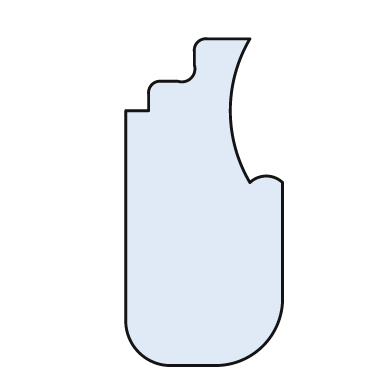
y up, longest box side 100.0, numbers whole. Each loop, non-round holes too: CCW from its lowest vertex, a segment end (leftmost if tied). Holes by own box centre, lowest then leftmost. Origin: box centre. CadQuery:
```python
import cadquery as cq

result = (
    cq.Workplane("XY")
    .moveTo(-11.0, -50.0)
    .lineTo(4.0, -50.0)
    .threePointArc((18.0, -44.0), (24.0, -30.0))
    .lineTo(24.0, 6.0)
    .threePointArc((19.0, 8.0), (14.0, 6.0))
    .threePointArc((8.0, 28.0), (14.0, 50.0))
    .lineTo(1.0, 50.0)
    .threePointArc((-2.0, 49.0), (-3.0, 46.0))
    .lineTo(-3.0, 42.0)
    .threePointArc((-4.0, 38.0), (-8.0, 37.0))
    .lineTo(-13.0, 37.0)
    .threePointArc((-16.0, 36.0), (-17.0, 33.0))
    .lineTo(-17.0, 28.0)
    .lineTo(-24.0, 28.0)
    .lineTo(-24.0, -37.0)
    .threePointArc((-20.0, -46.0), (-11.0, -50.0))
    .close()
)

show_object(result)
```